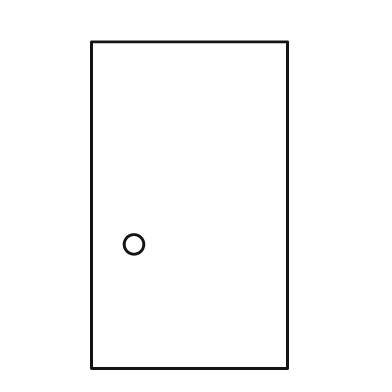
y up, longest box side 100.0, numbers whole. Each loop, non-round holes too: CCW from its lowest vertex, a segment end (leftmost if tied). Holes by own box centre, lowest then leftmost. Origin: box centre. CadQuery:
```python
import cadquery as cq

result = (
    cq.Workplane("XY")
    .moveTo(-30.0, -50.0)
    .lineTo(30.0, -50.0)
    .lineTo(30.0, 50.0)
    .lineTo(-30.0, 50.0)
    .close()
    .moveTo(-17.0, -12.0)
    .circle(3.0)
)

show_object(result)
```